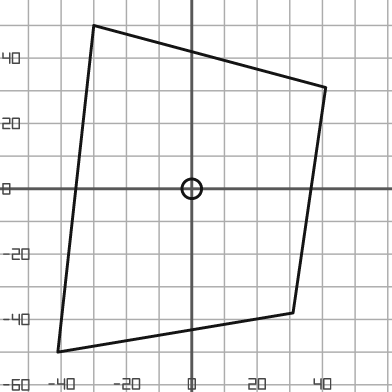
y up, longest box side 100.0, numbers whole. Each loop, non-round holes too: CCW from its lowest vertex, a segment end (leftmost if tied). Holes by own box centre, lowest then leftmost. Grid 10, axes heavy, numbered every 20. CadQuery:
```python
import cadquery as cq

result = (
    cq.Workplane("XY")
    .moveTo(-41.0, -50.0)
    .lineTo(31.0, -38.0)
    .lineTo(41.0, 31.0)
    .lineTo(-30.0, 50.0)
    .close()
    .moveTo(0.0, 0.0)
    .circle(3.0)
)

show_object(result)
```